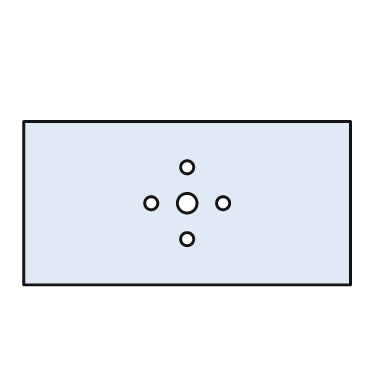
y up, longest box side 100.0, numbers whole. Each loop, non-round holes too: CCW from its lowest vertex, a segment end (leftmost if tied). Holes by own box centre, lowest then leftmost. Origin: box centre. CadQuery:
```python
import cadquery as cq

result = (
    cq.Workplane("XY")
    .moveTo(-50.0, -25.0)
    .lineTo(50.0, -25.0)
    .lineTo(50.0, 25.0)
    .lineTo(-50.0, 25.0)
    .close()
    .moveTo(0.0, -11.0)
    .circle(2.0)
    .moveTo(-11.0, 0.0)
    .circle(2.0)
    .moveTo(0.0, 0.0)
    .circle(3.0)
    .moveTo(11.0, 0.0)
    .circle(2.0)
    .moveTo(0.0, 11.0)
    .circle(2.0)
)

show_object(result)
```